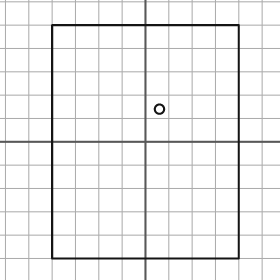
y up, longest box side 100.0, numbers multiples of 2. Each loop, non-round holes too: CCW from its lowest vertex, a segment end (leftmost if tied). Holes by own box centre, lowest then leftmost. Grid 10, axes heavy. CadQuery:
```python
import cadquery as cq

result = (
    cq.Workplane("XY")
    .moveTo(-40.0, -50.0)
    .lineTo(40.0, -50.0)
    .lineTo(40.0, 50.0)
    .lineTo(-40.0, 50.0)
    .close()
    .moveTo(6.0, 14.0)
    .circle(2.0)
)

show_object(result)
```